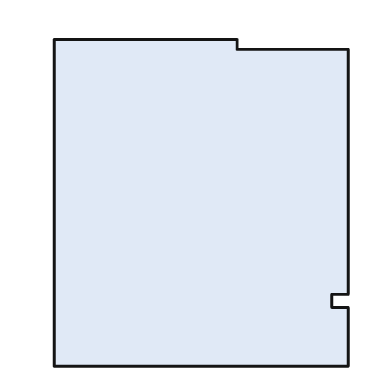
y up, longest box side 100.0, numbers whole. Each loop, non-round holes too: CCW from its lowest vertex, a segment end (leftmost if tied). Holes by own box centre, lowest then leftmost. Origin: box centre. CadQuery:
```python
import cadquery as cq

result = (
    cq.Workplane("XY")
    .moveTo(-45.0, -50.0)
    .lineTo(45.0, -50.0)
    .lineTo(45.0, -32.0)
    .lineTo(40.0, -32.0)
    .lineTo(40.0, -28.0)
    .lineTo(45.0, -28.0)
    .lineTo(45.0, 47.0)
    .lineTo(11.0, 47.0)
    .lineTo(11.0, 50.0)
    .lineTo(-45.0, 50.0)
    .close()
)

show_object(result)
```